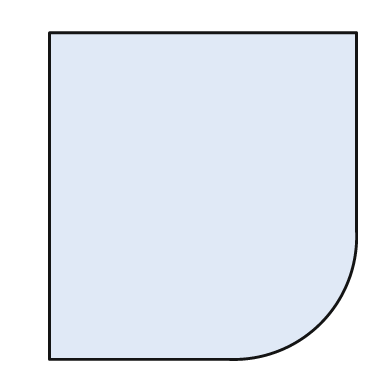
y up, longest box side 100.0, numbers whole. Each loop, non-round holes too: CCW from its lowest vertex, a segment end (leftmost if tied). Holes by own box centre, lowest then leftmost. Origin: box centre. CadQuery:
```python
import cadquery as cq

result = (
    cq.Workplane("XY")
    .moveTo(-47.0, -50.0)
    .lineTo(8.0, -50.0)
    .threePointArc((36.0, -39.0), (47.0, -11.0))
    .lineTo(47.0, 50.0)
    .lineTo(-47.0, 50.0)
    .close()
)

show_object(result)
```